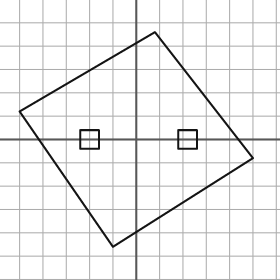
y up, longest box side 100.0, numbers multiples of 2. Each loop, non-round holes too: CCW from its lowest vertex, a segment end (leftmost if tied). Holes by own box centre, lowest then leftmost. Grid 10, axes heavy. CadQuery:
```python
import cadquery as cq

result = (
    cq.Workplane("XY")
    .moveTo(-10.0, -46.0)
    .lineTo(50.0, -8.0)
    .lineTo(8.0, 46.0)
    .lineTo(-50.0, 12.0)
    .close()
    .moveTo(-24.0, -4.0)
    .lineTo(-16.0, -4.0)
    .lineTo(-16.0, 4.0)
    .lineTo(-24.0, 4.0)
    .close()
    .moveTo(18.0, -4.0)
    .lineTo(26.0, -4.0)
    .lineTo(26.0, 4.0)
    .lineTo(18.0, 4.0)
    .close()
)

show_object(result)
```